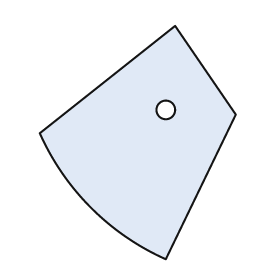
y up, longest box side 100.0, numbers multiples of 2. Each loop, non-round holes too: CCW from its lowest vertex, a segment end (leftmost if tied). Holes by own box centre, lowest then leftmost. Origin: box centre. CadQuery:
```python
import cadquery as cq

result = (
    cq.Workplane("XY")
    .moveTo(12.0, -50.0)
    .lineTo(42.0, 12.0)
    .lineTo(16.0, 50.0)
    .lineTo(-42.0, 4.0)
    .threePointArc((-20.0, -28.0), (12.0, -50.0))
    .close()
    .moveTo(12.0, 14.0)
    .circle(4.0)
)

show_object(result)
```